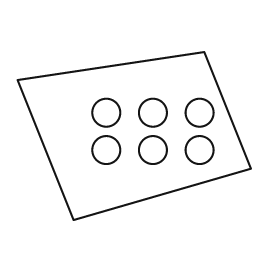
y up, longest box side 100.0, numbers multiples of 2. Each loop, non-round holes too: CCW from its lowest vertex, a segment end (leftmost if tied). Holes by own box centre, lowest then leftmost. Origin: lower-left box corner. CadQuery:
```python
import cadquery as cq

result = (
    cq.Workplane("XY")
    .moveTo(24.0, 0.0)
    .lineTo(100.0, 22.0)
    .lineTo(80.0, 72.0)
    .lineTo(0.0, 60.0)
    .close()
    .moveTo(38.0, 30.0)
    .circle(6.0)
    .moveTo(58.0, 30.0)
    .circle(6.0)
    .moveTo(78.0, 30.0)
    .circle(6.0)
    .moveTo(38.0, 46.0)
    .circle(6.0)
    .moveTo(58.0, 46.0)
    .circle(6.0)
    .moveTo(78.0, 46.0)
    .circle(6.0)
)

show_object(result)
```